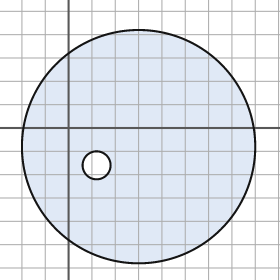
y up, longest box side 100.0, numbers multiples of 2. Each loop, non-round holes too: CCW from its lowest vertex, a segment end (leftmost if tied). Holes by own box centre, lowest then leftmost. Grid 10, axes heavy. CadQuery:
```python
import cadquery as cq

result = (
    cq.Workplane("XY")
    .moveTo(30.0, -8.0)
    .circle(50.0)
    .moveTo(12.0, -16.0)
    .circle(6.0)
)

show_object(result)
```